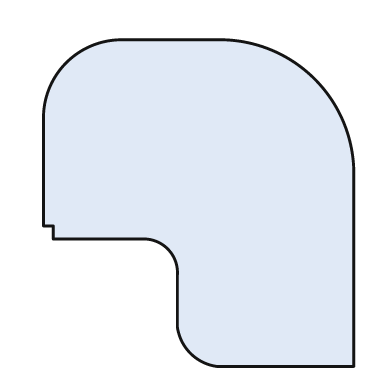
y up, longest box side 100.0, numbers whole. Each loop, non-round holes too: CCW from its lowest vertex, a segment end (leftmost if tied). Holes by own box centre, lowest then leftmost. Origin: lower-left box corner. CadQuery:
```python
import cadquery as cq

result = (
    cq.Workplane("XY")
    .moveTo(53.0, 0.0)
    .lineTo(95.0, 0.0)
    .lineTo(95.0, 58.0)
    .threePointArc((83.0, 88.0), (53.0, 100.0))
    .lineTo(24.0, 100.0)
    .threePointArc((7.0, 93.0), (0.0, 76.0))
    .lineTo(0.0, 43.0)
    .lineTo(3.0, 43.0)
    .lineTo(3.0, 39.0)
    .lineTo(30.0, 39.0)
    .threePointArc((38.0, 36.0), (41.0, 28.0))
    .lineTo(41.0, 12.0)
    .threePointArc((45.0, 4.0), (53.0, 0.0))
    .close()
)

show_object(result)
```